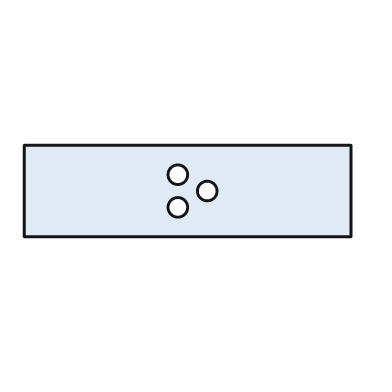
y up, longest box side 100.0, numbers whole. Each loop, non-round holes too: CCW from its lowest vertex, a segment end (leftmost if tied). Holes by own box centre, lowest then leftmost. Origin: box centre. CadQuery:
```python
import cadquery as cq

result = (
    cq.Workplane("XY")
    .moveTo(-50.0, -14.0)
    .lineTo(50.0, -14.0)
    .lineTo(50.0, 14.0)
    .lineTo(-50.0, 14.0)
    .close()
    .moveTo(-3.0, -5.0)
    .circle(3.0)
    .moveTo(6.0, 0.0)
    .circle(3.0)
    .moveTo(-3.0, 5.0)
    .circle(3.0)
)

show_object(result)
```